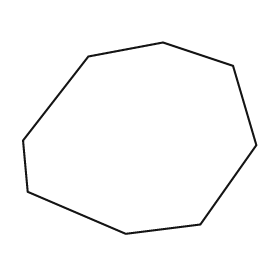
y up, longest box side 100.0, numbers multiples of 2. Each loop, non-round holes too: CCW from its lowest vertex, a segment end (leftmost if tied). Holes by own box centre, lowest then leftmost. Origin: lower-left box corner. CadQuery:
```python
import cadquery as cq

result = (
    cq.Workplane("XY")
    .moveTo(44.0, 0.0)
    .lineTo(76.0, 4.0)
    .lineTo(100.0, 38.0)
    .lineTo(90.0, 72.0)
    .lineTo(60.0, 82.0)
    .lineTo(28.0, 76.0)
    .lineTo(0.0, 40.0)
    .lineTo(2.0, 18.0)
    .close()
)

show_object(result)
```